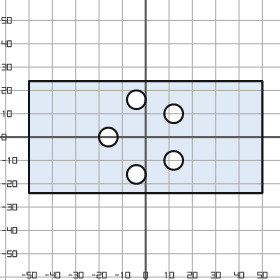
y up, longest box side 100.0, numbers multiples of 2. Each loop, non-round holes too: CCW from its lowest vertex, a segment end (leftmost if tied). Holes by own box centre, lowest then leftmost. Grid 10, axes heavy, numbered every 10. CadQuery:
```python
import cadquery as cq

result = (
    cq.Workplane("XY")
    .moveTo(-50.0, -24.0)
    .lineTo(50.0, -24.0)
    .lineTo(50.0, 24.0)
    .lineTo(-50.0, 24.0)
    .close()
    .moveTo(-4.0, -16.0)
    .circle(4.0)
    .moveTo(12.0, -10.0)
    .circle(4.0)
    .moveTo(-16.0, 0.0)
    .circle(4.0)
    .moveTo(12.0, 10.0)
    .circle(4.0)
    .moveTo(-4.0, 16.0)
    .circle(4.0)
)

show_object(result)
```